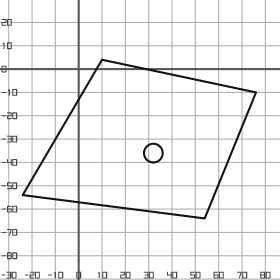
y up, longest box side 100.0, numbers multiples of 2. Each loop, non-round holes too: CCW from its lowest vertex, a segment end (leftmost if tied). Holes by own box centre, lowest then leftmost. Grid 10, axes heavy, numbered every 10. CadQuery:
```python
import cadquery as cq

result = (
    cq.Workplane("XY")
    .moveTo(54.0, -64.0)
    .lineTo(76.0, -10.0)
    .lineTo(10.0, 4.0)
    .lineTo(-24.0, -54.0)
    .close()
    .moveTo(32.0, -36.0)
    .circle(4.0)
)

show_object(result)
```